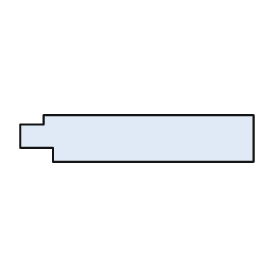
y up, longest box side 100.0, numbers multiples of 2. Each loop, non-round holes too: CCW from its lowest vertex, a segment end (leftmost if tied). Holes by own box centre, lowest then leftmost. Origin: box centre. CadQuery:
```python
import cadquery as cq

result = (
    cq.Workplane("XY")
    .moveTo(-36.0, -10.0)
    .lineTo(50.0, -10.0)
    .lineTo(50.0, 10.0)
    .lineTo(-40.0, 10.0)
    .lineTo(-40.0, 6.0)
    .lineTo(-50.0, 6.0)
    .lineTo(-50.0, -4.0)
    .lineTo(-36.0, -4.0)
    .close()
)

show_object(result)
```